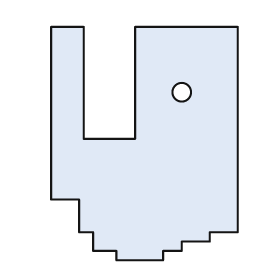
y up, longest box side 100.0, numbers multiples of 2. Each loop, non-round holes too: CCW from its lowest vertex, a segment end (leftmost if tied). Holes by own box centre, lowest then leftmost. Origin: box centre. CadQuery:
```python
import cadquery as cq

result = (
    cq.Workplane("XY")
    .moveTo(-12.0, -50.0)
    .lineTo(8.0, -50.0)
    .lineTo(8.0, -46.0)
    .lineTo(16.0, -46.0)
    .lineTo(16.0, -42.0)
    .lineTo(28.0, -42.0)
    .lineTo(28.0, -38.0)
    .lineTo(40.0, -38.0)
    .lineTo(40.0, 50.0)
    .lineTo(-4.0, 50.0)
    .lineTo(-4.0, 2.0)
    .lineTo(-26.0, 2.0)
    .lineTo(-26.0, 50.0)
    .lineTo(-40.0, 50.0)
    .lineTo(-40.0, -24.0)
    .lineTo(-28.0, -24.0)
    .lineTo(-28.0, -38.0)
    .lineTo(-22.0, -38.0)
    .lineTo(-22.0, -46.0)
    .lineTo(-12.0, -46.0)
    .close()
    .moveTo(16.0, 22.0)
    .circle(4.0)
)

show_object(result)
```